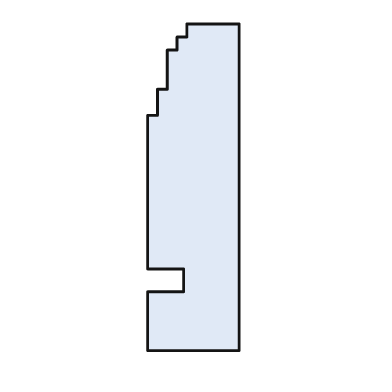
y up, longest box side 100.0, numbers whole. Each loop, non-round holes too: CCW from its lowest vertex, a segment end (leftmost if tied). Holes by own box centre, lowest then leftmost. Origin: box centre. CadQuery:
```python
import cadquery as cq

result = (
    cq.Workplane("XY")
    .moveTo(-14.0, -50.0)
    .lineTo(14.0, -50.0)
    .lineTo(14.0, 50.0)
    .lineTo(-2.0, 50.0)
    .lineTo(-2.0, 46.0)
    .lineTo(-5.0, 46.0)
    .lineTo(-5.0, 42.0)
    .lineTo(-8.0, 42.0)
    .lineTo(-8.0, 30.0)
    .lineTo(-11.0, 30.0)
    .lineTo(-11.0, 22.0)
    .lineTo(-14.0, 22.0)
    .lineTo(-14.0, -25.0)
    .lineTo(-3.0, -25.0)
    .lineTo(-3.0, -32.0)
    .lineTo(-14.0, -32.0)
    .close()
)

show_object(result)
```